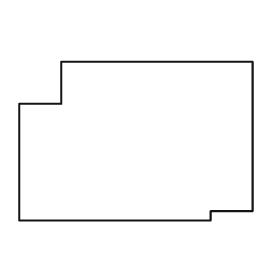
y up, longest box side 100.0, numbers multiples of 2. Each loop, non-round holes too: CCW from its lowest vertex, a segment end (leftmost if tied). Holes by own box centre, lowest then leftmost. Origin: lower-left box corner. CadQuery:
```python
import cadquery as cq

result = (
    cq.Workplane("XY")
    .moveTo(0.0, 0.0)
    .lineTo(82.0, 0.0)
    .lineTo(82.0, 4.0)
    .lineTo(100.0, 4.0)
    .lineTo(100.0, 68.0)
    .lineTo(18.0, 68.0)
    .lineTo(18.0, 50.0)
    .lineTo(0.0, 50.0)
    .close()
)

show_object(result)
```